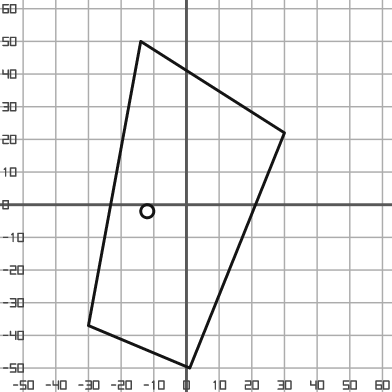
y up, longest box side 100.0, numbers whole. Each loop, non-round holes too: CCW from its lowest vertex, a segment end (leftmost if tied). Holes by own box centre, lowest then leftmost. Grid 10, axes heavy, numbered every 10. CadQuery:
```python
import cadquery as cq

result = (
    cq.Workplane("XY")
    .moveTo(1.0, -50.0)
    .lineTo(30.0, 22.0)
    .lineTo(-14.0, 50.0)
    .lineTo(-30.0, -37.0)
    .close()
    .moveTo(-12.0, -2.0)
    .circle(2.0)
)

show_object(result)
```